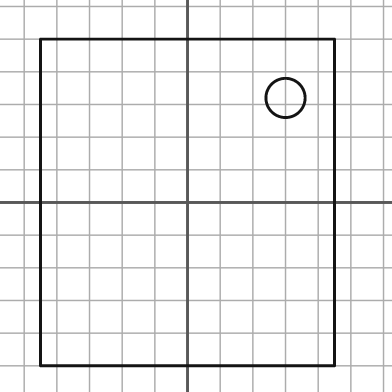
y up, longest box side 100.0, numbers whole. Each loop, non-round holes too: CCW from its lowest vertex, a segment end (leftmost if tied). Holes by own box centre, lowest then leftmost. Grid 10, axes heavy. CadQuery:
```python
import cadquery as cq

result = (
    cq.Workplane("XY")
    .moveTo(-45.0, -50.0)
    .lineTo(45.0, -50.0)
    .lineTo(45.0, 50.0)
    .lineTo(-45.0, 50.0)
    .close()
    .moveTo(30.0, 32.0)
    .circle(6.0)
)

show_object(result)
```